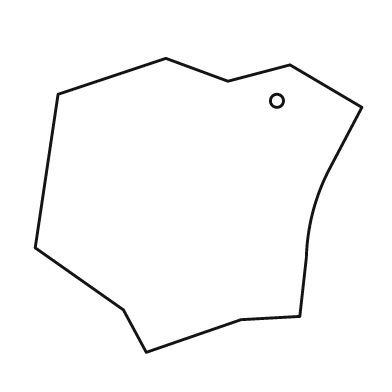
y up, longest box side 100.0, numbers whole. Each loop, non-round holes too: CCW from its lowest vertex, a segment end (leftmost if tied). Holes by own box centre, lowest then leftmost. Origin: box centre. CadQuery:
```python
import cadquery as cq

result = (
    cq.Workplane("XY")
    .moveTo(-16.0, -45.0)
    .lineTo(13.0, -35.0)
    .lineTo(31.0, -34.0)
    .lineTo(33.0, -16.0)
    .threePointArc((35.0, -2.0), (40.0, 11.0))
    .lineTo(50.0, 30.0)
    .lineTo(28.0, 43.0)
    .lineTo(9.0, 38.0)
    .lineTo(-10.0, 45.0)
    .lineTo(-43.0, 34.0)
    .lineTo(-50.0, -13.0)
    .lineTo(-23.0, -32.0)
    .close()
    .moveTo(24.0, 32.0)
    .circle(2.0)
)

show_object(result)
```